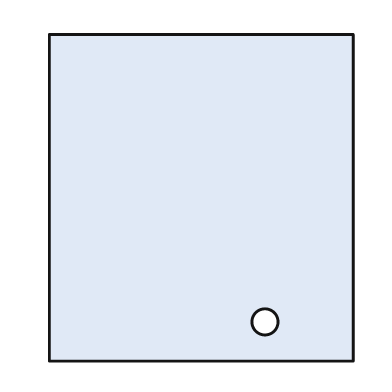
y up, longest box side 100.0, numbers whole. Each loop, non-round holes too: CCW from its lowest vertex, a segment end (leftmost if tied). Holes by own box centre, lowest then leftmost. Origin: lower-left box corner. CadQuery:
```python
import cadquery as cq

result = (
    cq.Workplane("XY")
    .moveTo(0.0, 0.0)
    .lineTo(93.0, 0.0)
    .lineTo(93.0, 100.0)
    .lineTo(0.0, 100.0)
    .close()
    .moveTo(66.0, 12.0)
    .circle(4.0)
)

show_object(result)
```